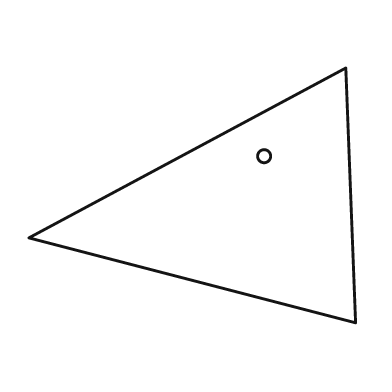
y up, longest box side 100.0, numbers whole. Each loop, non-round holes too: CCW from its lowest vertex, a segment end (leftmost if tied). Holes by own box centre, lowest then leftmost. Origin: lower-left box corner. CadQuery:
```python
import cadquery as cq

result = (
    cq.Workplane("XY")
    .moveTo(100.0, 0.0)
    .lineTo(97.0, 78.0)
    .lineTo(0.0, 26.0)
    .close()
    .moveTo(72.0, 51.0)
    .circle(2.0)
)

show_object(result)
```